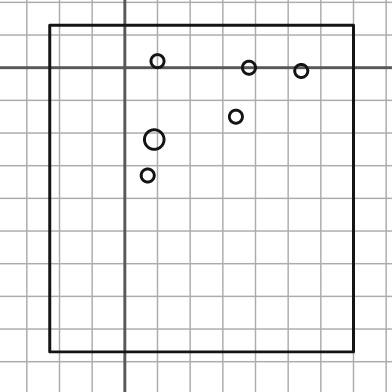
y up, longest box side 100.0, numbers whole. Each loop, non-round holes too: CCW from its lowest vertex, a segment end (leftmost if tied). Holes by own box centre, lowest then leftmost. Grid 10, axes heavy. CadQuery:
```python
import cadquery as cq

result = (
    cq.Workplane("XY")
    .moveTo(-23.0, -87.0)
    .lineTo(70.0, -87.0)
    .lineTo(70.0, 13.0)
    .lineTo(-23.0, 13.0)
    .close()
    .moveTo(7.0, -33.0)
    .circle(2.0)
    .moveTo(9.0, -22.0)
    .circle(3.0)
    .moveTo(34.0, -15.0)
    .circle(2.0)
    .moveTo(54.0, -1.0)
    .circle(2.0)
    .moveTo(38.0, 0.0)
    .circle(2.0)
    .moveTo(10.0, 2.0)
    .circle(2.0)
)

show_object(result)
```